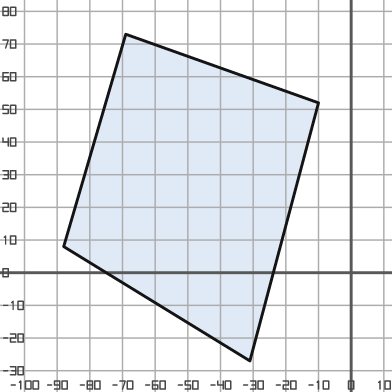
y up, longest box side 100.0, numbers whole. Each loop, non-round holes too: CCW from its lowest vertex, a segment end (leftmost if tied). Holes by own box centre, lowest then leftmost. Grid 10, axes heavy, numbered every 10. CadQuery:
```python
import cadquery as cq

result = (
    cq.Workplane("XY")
    .moveTo(-31.0, -27.0)
    .lineTo(-10.0, 52.0)
    .lineTo(-69.0, 73.0)
    .lineTo(-88.0, 8.0)
    .close()
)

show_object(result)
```